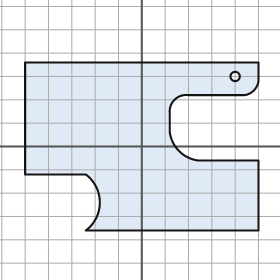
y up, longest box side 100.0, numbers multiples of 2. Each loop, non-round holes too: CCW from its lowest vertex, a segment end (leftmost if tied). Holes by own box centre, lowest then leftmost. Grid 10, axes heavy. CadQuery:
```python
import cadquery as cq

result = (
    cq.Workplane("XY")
    .moveTo(-24.0, -36.0)
    .lineTo(50.0, -36.0)
    .lineTo(50.0, -6.0)
    .lineTo(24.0, -6.0)
    .threePointArc((16.0, -2.0), (12.0, 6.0))
    .lineTo(12.0, 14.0)
    .threePointArc((14.0, 20.0), (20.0, 22.0))
    .lineTo(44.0, 22.0)
    .threePointArc((48.0, 24.0), (50.0, 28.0))
    .lineTo(50.0, 36.0)
    .lineTo(-50.0, 36.0)
    .lineTo(-50.0, -12.0)
    .lineTo(-24.0, -12.0)
    .threePointArc((-18.0, -24.0), (-24.0, -36.0))
    .close()
    .moveTo(40.0, 30.0)
    .circle(2.0)
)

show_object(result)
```